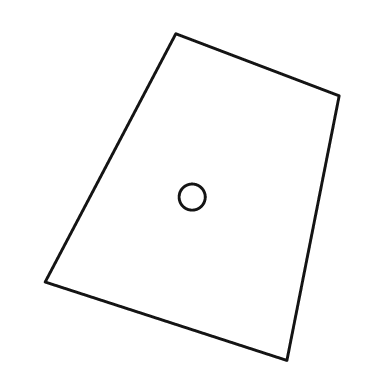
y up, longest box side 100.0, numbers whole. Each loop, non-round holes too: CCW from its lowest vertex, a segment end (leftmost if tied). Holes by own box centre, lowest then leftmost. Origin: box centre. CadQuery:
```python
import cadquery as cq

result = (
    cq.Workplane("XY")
    .moveTo(29.0, -50.0)
    .lineTo(45.0, 31.0)
    .lineTo(-5.0, 50.0)
    .lineTo(-45.0, -26.0)
    .close()
    .moveTo(0.0, 0.0)
    .circle(4.0)
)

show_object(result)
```